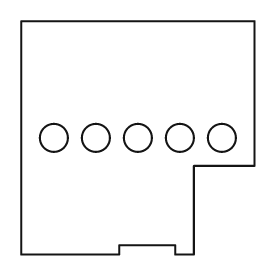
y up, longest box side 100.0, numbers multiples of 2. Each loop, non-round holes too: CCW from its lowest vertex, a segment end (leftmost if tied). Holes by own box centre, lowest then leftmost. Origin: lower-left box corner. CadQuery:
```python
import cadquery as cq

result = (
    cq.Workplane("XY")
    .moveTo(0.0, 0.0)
    .lineTo(42.0, 0.0)
    .lineTo(42.0, 4.0)
    .lineTo(66.0, 4.0)
    .lineTo(66.0, 0.0)
    .lineTo(74.0, 0.0)
    .lineTo(74.0, 38.0)
    .lineTo(100.0, 38.0)
    .lineTo(100.0, 100.0)
    .lineTo(0.0, 100.0)
    .close()
    .moveTo(14.0, 50.0)
    .circle(6.0)
    .moveTo(32.0, 50.0)
    .circle(6.0)
    .moveTo(50.0, 50.0)
    .circle(6.0)
    .moveTo(68.0, 50.0)
    .circle(6.0)
    .moveTo(86.0, 50.0)
    .circle(6.0)
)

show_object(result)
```